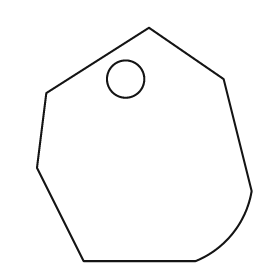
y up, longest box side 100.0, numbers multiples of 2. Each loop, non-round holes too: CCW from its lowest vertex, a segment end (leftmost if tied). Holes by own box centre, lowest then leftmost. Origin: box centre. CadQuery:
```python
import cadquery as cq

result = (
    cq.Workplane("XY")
    .moveTo(-26.0, -50.0)
    .lineTo(22.0, -50.0)
    .threePointArc((38.0, -38.0), (46.0, -20.0))
    .lineTo(34.0, 28.0)
    .lineTo(2.0, 50.0)
    .lineTo(-42.0, 22.0)
    .lineTo(-46.0, -10.0)
    .close()
    .moveTo(-8.0, 28.0)
    .circle(8.0)
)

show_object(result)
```